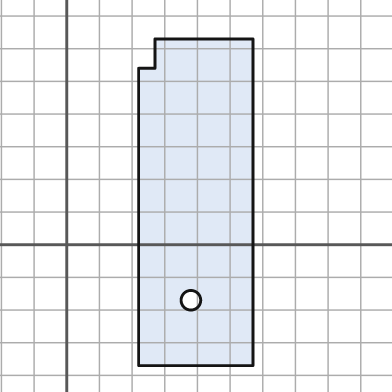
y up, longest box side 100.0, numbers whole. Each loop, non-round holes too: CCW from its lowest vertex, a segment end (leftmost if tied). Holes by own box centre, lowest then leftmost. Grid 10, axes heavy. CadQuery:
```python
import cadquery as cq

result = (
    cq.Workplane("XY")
    .moveTo(22.0, -37.0)
    .lineTo(57.0, -37.0)
    .lineTo(57.0, 63.0)
    .lineTo(27.0, 63.0)
    .lineTo(27.0, 54.0)
    .lineTo(22.0, 54.0)
    .close()
    .moveTo(38.0, -17.0)
    .circle(3.0)
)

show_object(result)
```